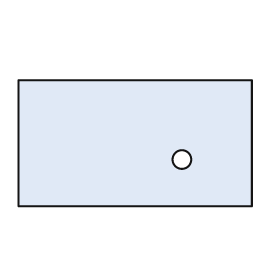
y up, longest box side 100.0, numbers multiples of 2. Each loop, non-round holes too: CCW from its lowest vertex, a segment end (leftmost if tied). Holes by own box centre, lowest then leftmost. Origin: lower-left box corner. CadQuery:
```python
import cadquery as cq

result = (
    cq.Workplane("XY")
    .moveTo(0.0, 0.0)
    .lineTo(100.0, 0.0)
    .lineTo(100.0, 54.0)
    .lineTo(0.0, 54.0)
    .close()
    .moveTo(70.0, 20.0)
    .circle(4.0)
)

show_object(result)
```